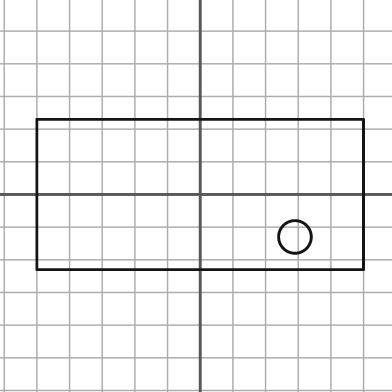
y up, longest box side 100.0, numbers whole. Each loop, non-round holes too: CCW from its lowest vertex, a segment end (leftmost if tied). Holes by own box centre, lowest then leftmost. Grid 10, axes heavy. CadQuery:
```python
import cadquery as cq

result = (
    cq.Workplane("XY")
    .moveTo(-50.0, -23.0)
    .lineTo(50.0, -23.0)
    .lineTo(50.0, 23.0)
    .lineTo(-50.0, 23.0)
    .close()
    .moveTo(29.0, -13.0)
    .circle(5.0)
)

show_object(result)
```